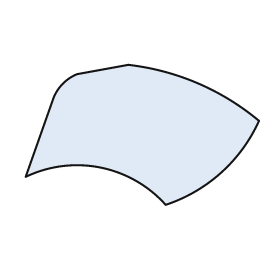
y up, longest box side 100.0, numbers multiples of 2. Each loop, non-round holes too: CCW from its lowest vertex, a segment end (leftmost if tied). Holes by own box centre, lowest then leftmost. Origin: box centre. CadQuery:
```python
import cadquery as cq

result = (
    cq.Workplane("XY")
    .moveTo(10.0, -30.0)
    .threePointArc((34.0, -16.0), (50.0, 6.0))
    .threePointArc((24.0, 22.0), (-6.0, 30.0))
    .lineTo(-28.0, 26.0)
    .threePointArc((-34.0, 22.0), (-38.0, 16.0))
    .lineTo(-50.0, -18.0)
    .threePointArc((-18.0, -14.0), (10.0, -30.0))
    .close()
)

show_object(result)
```